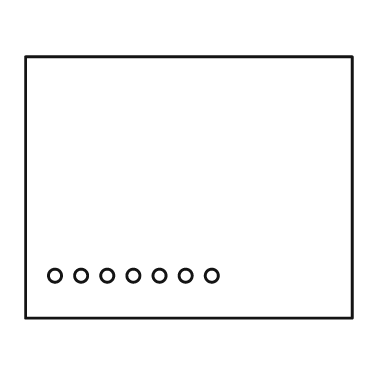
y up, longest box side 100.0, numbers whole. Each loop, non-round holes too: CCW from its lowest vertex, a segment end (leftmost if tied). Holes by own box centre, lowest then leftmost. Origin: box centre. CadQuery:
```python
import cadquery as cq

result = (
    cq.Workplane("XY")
    .moveTo(-50.0, -40.0)
    .lineTo(50.0, -40.0)
    .lineTo(50.0, 40.0)
    .lineTo(-50.0, 40.0)
    .close()
    .moveTo(-41.0, -27.0)
    .circle(2.0)
    .moveTo(-33.0, -27.0)
    .circle(2.0)
    .moveTo(-25.0, -27.0)
    .circle(2.0)
    .moveTo(-17.0, -27.0)
    .circle(2.0)
    .moveTo(-9.0, -27.0)
    .circle(2.0)
    .moveTo(-1.0, -27.0)
    .circle(2.0)
    .moveTo(7.0, -27.0)
    .circle(2.0)
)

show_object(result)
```